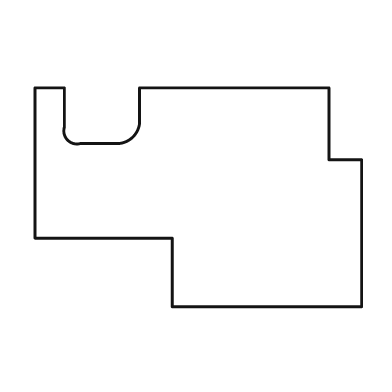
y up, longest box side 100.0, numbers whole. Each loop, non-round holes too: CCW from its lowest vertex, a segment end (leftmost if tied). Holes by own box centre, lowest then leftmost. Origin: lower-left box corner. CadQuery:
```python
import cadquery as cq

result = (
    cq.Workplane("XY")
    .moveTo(42.0, 0.0)
    .lineTo(100.0, 0.0)
    .lineTo(100.0, 45.0)
    .lineTo(90.0, 45.0)
    .lineTo(90.0, 67.0)
    .lineTo(32.0, 67.0)
    .lineTo(32.0, 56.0)
    .threePointArc((30.0, 52.0), (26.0, 50.0))
    .lineTo(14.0, 50.0)
    .threePointArc((10.0, 51.0), (9.0, 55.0))
    .lineTo(9.0, 67.0)
    .lineTo(0.0, 67.0)
    .lineTo(0.0, 21.0)
    .lineTo(42.0, 21.0)
    .close()
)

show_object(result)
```